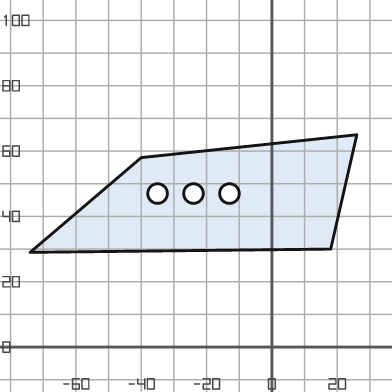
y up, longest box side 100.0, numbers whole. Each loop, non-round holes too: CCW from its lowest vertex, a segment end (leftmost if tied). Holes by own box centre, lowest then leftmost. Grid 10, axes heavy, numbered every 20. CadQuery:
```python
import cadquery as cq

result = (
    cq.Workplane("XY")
    .moveTo(-74.0, 29.0)
    .lineTo(18.0, 30.0)
    .lineTo(26.0, 65.0)
    .lineTo(-40.0, 58.0)
    .close()
    .moveTo(-35.0, 47.0)
    .circle(3.0)
    .moveTo(-24.0, 47.0)
    .circle(3.0)
    .moveTo(-13.0, 47.0)
    .circle(3.0)
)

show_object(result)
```